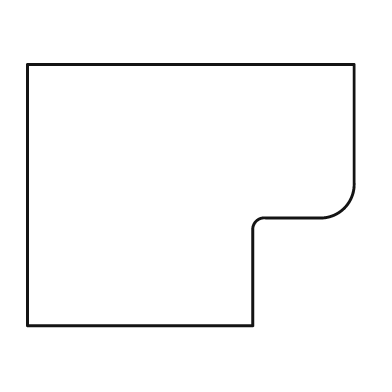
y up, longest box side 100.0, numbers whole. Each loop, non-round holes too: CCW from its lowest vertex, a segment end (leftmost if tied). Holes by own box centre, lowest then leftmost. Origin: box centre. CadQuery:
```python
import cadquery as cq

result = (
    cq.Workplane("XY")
    .moveTo(-50.0, -40.0)
    .lineTo(19.0, -40.0)
    .lineTo(19.0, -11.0)
    .threePointArc((20.0, -8.0), (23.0, -7.0))
    .lineTo(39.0, -7.0)
    .threePointArc((47.0, -4.0), (50.0, 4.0))
    .lineTo(50.0, 40.0)
    .lineTo(-50.0, 40.0)
    .close()
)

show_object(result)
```